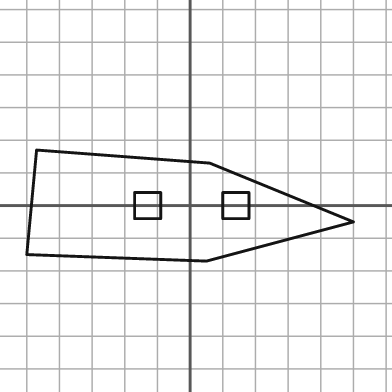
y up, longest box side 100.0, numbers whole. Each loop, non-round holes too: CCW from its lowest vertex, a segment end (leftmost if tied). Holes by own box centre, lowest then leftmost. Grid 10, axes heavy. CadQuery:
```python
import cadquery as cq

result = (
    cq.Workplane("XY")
    .moveTo(5.0, -17.0)
    .lineTo(50.0, -5.0)
    .lineTo(6.0, 13.0)
    .lineTo(-47.0, 17.0)
    .lineTo(-50.0, -15.0)
    .close()
    .moveTo(-17.0, -4.0)
    .lineTo(-9.0, -4.0)
    .lineTo(-9.0, 4.0)
    .lineTo(-17.0, 4.0)
    .close()
    .moveTo(10.0, -4.0)
    .lineTo(18.0, -4.0)
    .lineTo(18.0, 4.0)
    .lineTo(10.0, 4.0)
    .close()
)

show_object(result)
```